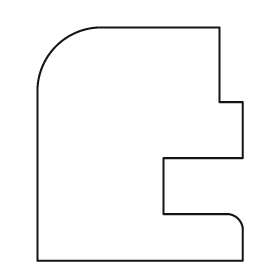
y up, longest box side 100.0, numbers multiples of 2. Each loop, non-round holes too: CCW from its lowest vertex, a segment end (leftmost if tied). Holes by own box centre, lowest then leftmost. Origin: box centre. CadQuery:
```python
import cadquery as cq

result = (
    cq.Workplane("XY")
    .moveTo(-44.0, -50.0)
    .lineTo(44.0, -50.0)
    .lineTo(44.0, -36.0)
    .threePointArc((42.0, -32.0), (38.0, -30.0))
    .lineTo(10.0, -30.0)
    .lineTo(10.0, -6.0)
    .lineTo(44.0, -6.0)
    .lineTo(44.0, 18.0)
    .lineTo(34.0, 18.0)
    .lineTo(34.0, 50.0)
    .lineTo(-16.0, 50.0)
    .threePointArc((-36.0, 42.0), (-44.0, 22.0))
    .close()
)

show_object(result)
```